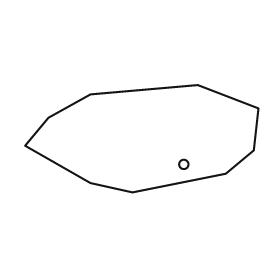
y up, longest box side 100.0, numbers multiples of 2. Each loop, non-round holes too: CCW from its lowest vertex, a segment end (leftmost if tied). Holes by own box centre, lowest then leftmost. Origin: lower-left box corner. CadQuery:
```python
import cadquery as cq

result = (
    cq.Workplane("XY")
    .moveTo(46.0, 0.0)
    .lineTo(86.0, 8.0)
    .lineTo(98.0, 18.0)
    .lineTo(100.0, 36.0)
    .lineTo(74.0, 46.0)
    .lineTo(28.0, 42.0)
    .lineTo(10.0, 32.0)
    .lineTo(0.0, 20.0)
    .lineTo(28.0, 4.0)
    .close()
    .moveTo(68.0, 12.0)
    .circle(2.0)
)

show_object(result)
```